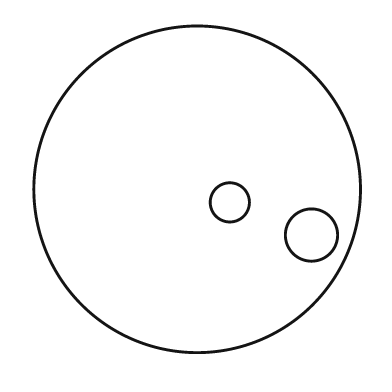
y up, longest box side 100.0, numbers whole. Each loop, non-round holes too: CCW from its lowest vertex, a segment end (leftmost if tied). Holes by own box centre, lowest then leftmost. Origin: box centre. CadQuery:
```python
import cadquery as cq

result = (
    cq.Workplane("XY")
    .moveTo(0.0, 0.0)
    .circle(50.0)
    .moveTo(35.0, -14.0)
    .circle(8.0)
    .moveTo(10.0, -4.0)
    .circle(6.0)
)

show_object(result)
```